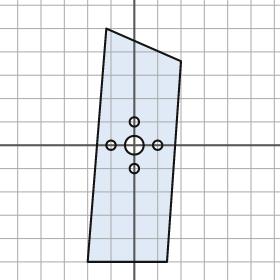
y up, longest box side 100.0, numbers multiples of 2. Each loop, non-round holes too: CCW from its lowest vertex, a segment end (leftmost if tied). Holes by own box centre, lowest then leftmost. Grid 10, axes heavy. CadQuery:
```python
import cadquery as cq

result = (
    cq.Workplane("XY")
    .moveTo(-20.0, -50.0)
    .lineTo(14.0, -50.0)
    .lineTo(20.0, 36.0)
    .lineTo(-12.0, 50.0)
    .close()
    .moveTo(0.0, -10.0)
    .circle(2.0)
    .moveTo(-10.0, 0.0)
    .circle(2.0)
    .moveTo(0.0, 0.0)
    .circle(4.0)
    .moveTo(10.0, 0.0)
    .circle(2.0)
    .moveTo(0.0, 10.0)
    .circle(2.0)
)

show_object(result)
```